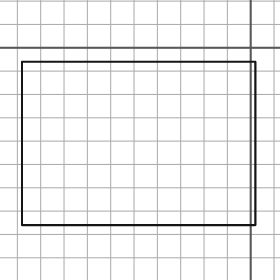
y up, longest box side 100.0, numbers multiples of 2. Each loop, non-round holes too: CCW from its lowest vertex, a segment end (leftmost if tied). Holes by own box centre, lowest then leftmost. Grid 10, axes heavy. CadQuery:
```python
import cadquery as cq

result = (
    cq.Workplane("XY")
    .moveTo(-98.0, -76.0)
    .lineTo(2.0, -76.0)
    .lineTo(2.0, -6.0)
    .lineTo(-98.0, -6.0)
    .close()
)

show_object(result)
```